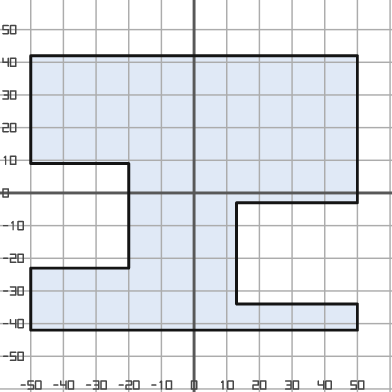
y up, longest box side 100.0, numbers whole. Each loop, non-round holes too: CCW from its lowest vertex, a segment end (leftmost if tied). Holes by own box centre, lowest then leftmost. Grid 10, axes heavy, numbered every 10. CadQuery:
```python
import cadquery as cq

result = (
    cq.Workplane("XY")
    .moveTo(-50.0, -42.0)
    .lineTo(50.0, -42.0)
    .lineTo(50.0, -34.0)
    .lineTo(13.0, -34.0)
    .lineTo(13.0, -3.0)
    .lineTo(50.0, -3.0)
    .lineTo(50.0, 42.0)
    .lineTo(-50.0, 42.0)
    .lineTo(-50.0, 9.0)
    .lineTo(-20.0, 9.0)
    .lineTo(-20.0, -23.0)
    .lineTo(-50.0, -23.0)
    .close()
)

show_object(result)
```